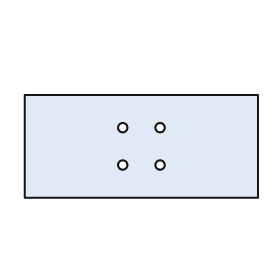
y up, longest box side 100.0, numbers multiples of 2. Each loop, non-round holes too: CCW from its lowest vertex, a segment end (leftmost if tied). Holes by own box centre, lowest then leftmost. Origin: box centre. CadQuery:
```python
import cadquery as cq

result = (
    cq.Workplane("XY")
    .moveTo(-50.0, -22.0)
    .lineTo(50.0, -22.0)
    .lineTo(50.0, 22.0)
    .lineTo(-50.0, 22.0)
    .close()
    .moveTo(-8.0, -8.0)
    .circle(2.0)
    .moveTo(8.0, -8.0)
    .circle(2.0)
    .moveTo(-8.0, 8.0)
    .circle(2.0)
    .moveTo(8.0, 8.0)
    .circle(2.0)
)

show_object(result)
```